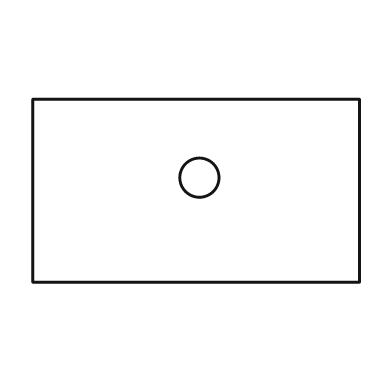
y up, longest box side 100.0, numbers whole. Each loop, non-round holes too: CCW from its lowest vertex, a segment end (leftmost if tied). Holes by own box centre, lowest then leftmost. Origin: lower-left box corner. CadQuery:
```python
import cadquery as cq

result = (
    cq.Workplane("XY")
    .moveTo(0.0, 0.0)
    .lineTo(100.0, 0.0)
    .lineTo(100.0, 56.0)
    .lineTo(0.0, 56.0)
    .close()
    .moveTo(51.0, 32.0)
    .circle(6.0)
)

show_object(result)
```